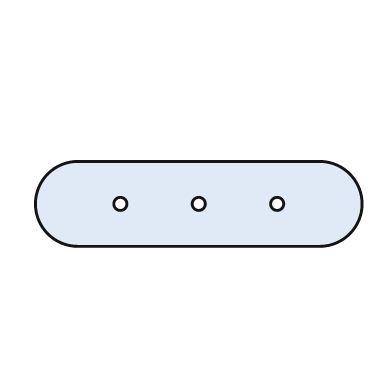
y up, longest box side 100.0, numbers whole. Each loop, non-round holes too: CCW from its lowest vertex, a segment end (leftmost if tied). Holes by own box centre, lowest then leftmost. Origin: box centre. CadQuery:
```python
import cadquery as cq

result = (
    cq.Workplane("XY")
    .moveTo(-37.0, -13.0)
    .lineTo(37.0, -13.0)
    .threePointArc((50.0, 0.0), (37.0, 13.0))
    .lineTo(-37.0, 13.0)
    .threePointArc((-50.0, 0.0), (-37.0, -13.0))
    .close()
    .moveTo(-24.0, 0.0)
    .circle(2.0)
    .moveTo(0.0, 0.0)
    .circle(2.0)
    .moveTo(24.0, 0.0)
    .circle(2.0)
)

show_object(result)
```